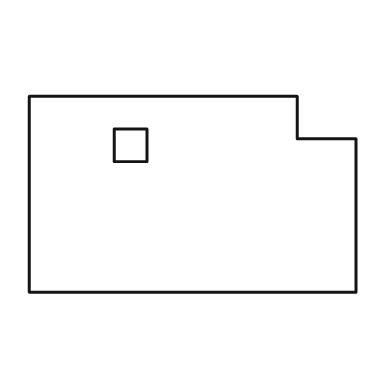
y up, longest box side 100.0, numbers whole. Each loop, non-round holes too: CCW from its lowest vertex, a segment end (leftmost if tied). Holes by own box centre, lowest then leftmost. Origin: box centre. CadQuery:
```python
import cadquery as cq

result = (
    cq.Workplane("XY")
    .moveTo(-50.0, -30.0)
    .lineTo(50.0, -30.0)
    .lineTo(50.0, 17.0)
    .lineTo(32.0, 17.0)
    .lineTo(32.0, 30.0)
    .lineTo(-50.0, 30.0)
    .close()
    .moveTo(-24.0, 10.0)
    .lineTo(-14.0, 10.0)
    .lineTo(-14.0, 20.0)
    .lineTo(-24.0, 20.0)
    .close()
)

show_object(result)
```